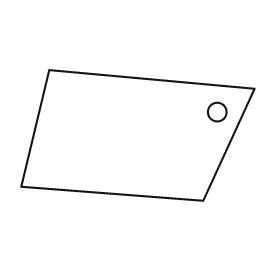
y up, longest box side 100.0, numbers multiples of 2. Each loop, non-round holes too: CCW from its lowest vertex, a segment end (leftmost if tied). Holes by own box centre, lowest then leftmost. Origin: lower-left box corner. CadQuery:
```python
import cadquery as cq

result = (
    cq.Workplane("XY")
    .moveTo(78.0, 0.0)
    .lineTo(100.0, 48.0)
    .lineTo(12.0, 56.0)
    .lineTo(0.0, 6.0)
    .close()
    .moveTo(84.0, 38.0)
    .circle(4.0)
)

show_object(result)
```